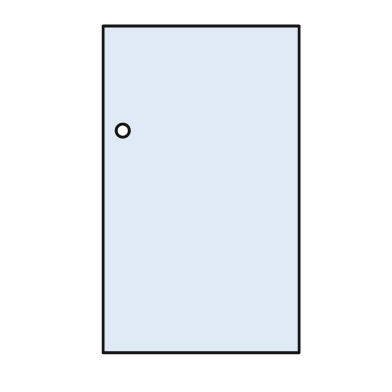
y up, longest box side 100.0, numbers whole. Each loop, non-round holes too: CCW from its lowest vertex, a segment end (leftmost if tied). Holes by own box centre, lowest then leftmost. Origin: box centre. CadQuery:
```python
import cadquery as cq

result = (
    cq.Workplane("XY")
    .moveTo(-30.0, -50.0)
    .lineTo(30.0, -50.0)
    .lineTo(30.0, 50.0)
    .lineTo(-30.0, 50.0)
    .close()
    .moveTo(-24.0, 18.0)
    .circle(2.0)
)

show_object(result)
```